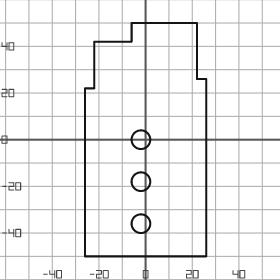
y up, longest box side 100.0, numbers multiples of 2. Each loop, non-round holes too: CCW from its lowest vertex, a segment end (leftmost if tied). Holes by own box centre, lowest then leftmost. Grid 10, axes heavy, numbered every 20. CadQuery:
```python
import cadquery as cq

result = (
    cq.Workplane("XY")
    .moveTo(-26.0, -50.0)
    .lineTo(26.0, -50.0)
    .lineTo(26.0, 26.0)
    .lineTo(22.0, 26.0)
    .lineTo(22.0, 50.0)
    .lineTo(-6.0, 50.0)
    .lineTo(-6.0, 42.0)
    .lineTo(-22.0, 42.0)
    .lineTo(-22.0, 22.0)
    .lineTo(-26.0, 22.0)
    .close()
    .moveTo(-2.0, -36.0)
    .circle(4.0)
    .moveTo(-2.0, -18.0)
    .circle(4.0)
    .moveTo(-2.0, 0.0)
    .circle(4.0)
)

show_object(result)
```